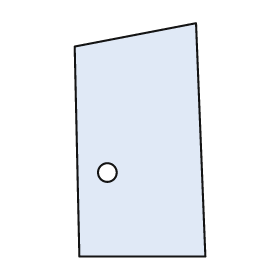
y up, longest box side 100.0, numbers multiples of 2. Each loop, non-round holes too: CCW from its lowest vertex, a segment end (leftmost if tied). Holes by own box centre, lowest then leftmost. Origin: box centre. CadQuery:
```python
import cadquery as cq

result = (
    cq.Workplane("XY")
    .moveTo(-26.0, -50.0)
    .lineTo(28.0, -50.0)
    .lineTo(24.0, 50.0)
    .lineTo(-28.0, 40.0)
    .close()
    .moveTo(-14.0, -14.0)
    .circle(4.0)
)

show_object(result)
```